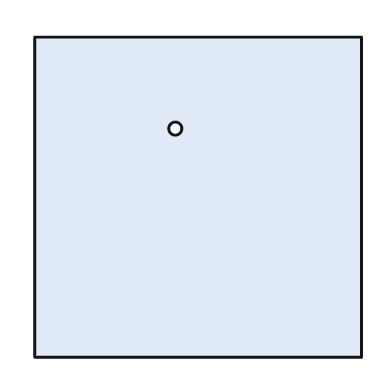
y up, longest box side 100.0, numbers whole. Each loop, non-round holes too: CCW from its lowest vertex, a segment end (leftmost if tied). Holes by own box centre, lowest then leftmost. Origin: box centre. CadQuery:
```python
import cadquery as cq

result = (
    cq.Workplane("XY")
    .moveTo(-50.0, -49.0)
    .lineTo(50.0, -49.0)
    .lineTo(50.0, 49.0)
    .lineTo(-50.0, 49.0)
    .close()
    .moveTo(-7.0, 21.0)
    .circle(2.0)
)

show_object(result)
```